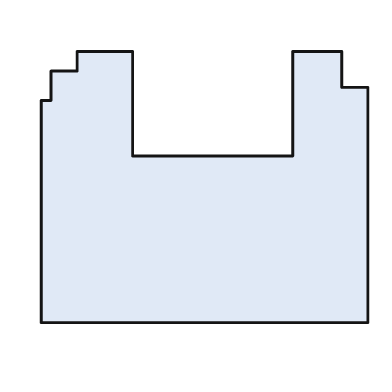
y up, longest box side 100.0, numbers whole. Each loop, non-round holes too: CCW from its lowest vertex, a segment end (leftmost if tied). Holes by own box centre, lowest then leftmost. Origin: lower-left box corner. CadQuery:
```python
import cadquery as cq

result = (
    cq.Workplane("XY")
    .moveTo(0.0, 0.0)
    .lineTo(100.0, 0.0)
    .lineTo(100.0, 72.0)
    .lineTo(92.0, 72.0)
    .lineTo(92.0, 83.0)
    .lineTo(77.0, 83.0)
    .lineTo(77.0, 51.0)
    .lineTo(28.0, 51.0)
    .lineTo(28.0, 83.0)
    .lineTo(11.0, 83.0)
    .lineTo(11.0, 77.0)
    .lineTo(3.0, 77.0)
    .lineTo(3.0, 68.0)
    .lineTo(0.0, 68.0)
    .close()
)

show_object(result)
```